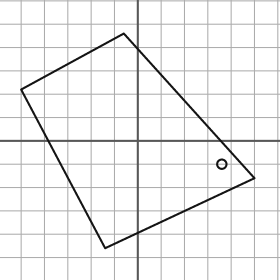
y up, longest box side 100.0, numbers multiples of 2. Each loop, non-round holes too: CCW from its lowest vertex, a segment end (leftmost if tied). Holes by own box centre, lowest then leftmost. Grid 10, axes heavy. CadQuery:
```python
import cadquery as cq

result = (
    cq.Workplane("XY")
    .moveTo(-14.0, -46.0)
    .lineTo(50.0, -16.0)
    .lineTo(-6.0, 46.0)
    .lineTo(-50.0, 22.0)
    .close()
    .moveTo(36.0, -10.0)
    .circle(2.0)
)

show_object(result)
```